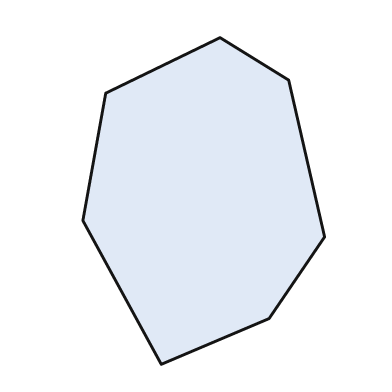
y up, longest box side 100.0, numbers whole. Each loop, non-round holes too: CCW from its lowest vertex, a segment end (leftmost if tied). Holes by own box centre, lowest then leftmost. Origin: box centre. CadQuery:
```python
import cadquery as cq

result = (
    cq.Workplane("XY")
    .moveTo(-13.0, -50.0)
    .lineTo(20.0, -36.0)
    .lineTo(37.0, -11.0)
    .lineTo(26.0, 37.0)
    .lineTo(5.0, 50.0)
    .lineTo(-30.0, 33.0)
    .lineTo(-37.0, -6.0)
    .close()
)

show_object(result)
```